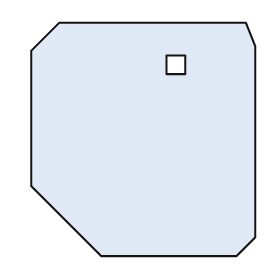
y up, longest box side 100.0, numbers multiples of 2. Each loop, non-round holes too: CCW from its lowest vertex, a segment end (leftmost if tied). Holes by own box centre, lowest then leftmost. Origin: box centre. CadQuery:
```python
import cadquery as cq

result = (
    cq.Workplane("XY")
    .moveTo(-18.0, -50.0)
    .lineTo(40.0, -50.0)
    .lineTo(48.0, -42.0)
    .lineTo(48.0, 40.0)
    .lineTo(44.0, 50.0)
    .lineTo(-36.0, 50.0)
    .lineTo(-48.0, 38.0)
    .lineTo(-48.0, -20.0)
    .close()
    .moveTo(10.0, 28.0)
    .lineTo(18.0, 28.0)
    .lineTo(18.0, 36.0)
    .lineTo(10.0, 36.0)
    .close()
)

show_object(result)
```